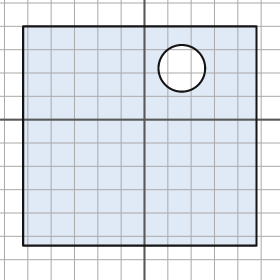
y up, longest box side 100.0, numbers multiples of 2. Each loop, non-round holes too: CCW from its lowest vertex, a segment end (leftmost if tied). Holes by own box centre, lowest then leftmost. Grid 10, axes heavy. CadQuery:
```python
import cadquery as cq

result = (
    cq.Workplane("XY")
    .moveTo(-52.0, -54.0)
    .lineTo(48.0, -54.0)
    .lineTo(48.0, 40.0)
    .lineTo(-52.0, 40.0)
    .close()
    .moveTo(16.0, 22.0)
    .circle(10.0)
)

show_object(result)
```